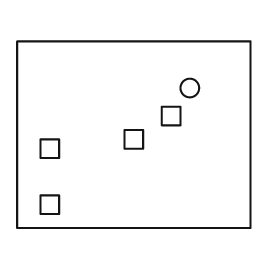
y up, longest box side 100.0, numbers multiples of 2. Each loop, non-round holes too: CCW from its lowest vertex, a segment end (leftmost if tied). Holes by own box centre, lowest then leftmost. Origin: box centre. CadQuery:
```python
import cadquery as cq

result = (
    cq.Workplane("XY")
    .moveTo(-50.0, -40.0)
    .lineTo(50.0, -40.0)
    .lineTo(50.0, 40.0)
    .lineTo(-50.0, 40.0)
    .close()
    .moveTo(-40.0, -34.0)
    .lineTo(-32.0, -34.0)
    .lineTo(-32.0, -26.0)
    .lineTo(-40.0, -26.0)
    .close()
    .moveTo(-40.0, -10.0)
    .lineTo(-32.0, -10.0)
    .lineTo(-32.0, -2.0)
    .lineTo(-40.0, -2.0)
    .close()
    .moveTo(-4.0, -6.0)
    .lineTo(4.0, -6.0)
    .lineTo(4.0, 2.0)
    .lineTo(-4.0, 2.0)
    .close()
    .moveTo(12.0, 4.0)
    .lineTo(20.0, 4.0)
    .lineTo(20.0, 12.0)
    .lineTo(12.0, 12.0)
    .close()
    .moveTo(24.0, 20.0)
    .circle(4.0)
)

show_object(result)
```